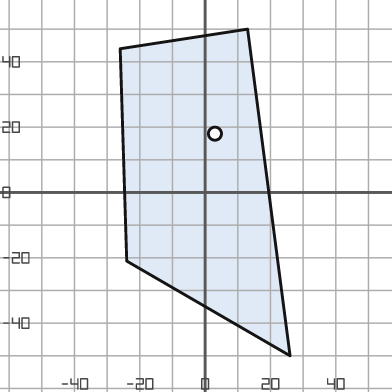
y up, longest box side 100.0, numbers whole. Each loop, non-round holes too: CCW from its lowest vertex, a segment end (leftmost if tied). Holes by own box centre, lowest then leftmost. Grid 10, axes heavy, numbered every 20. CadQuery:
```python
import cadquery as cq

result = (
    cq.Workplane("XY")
    .moveTo(26.0, -50.0)
    .lineTo(13.0, 50.0)
    .lineTo(-26.0, 44.0)
    .lineTo(-24.0, -21.0)
    .close()
    .moveTo(3.0, 18.0)
    .circle(2.0)
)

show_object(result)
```